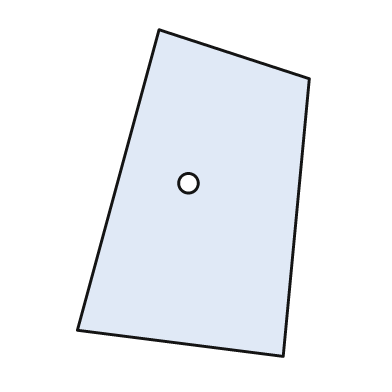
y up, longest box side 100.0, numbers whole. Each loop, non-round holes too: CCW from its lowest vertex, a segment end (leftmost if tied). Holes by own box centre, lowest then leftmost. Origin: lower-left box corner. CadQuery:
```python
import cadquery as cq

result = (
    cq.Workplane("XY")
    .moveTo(63.0, 0.0)
    .lineTo(71.0, 85.0)
    .lineTo(25.0, 100.0)
    .lineTo(0.0, 8.0)
    .close()
    .moveTo(34.0, 53.0)
    .circle(3.0)
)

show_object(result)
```